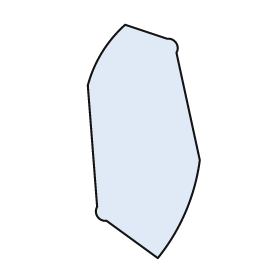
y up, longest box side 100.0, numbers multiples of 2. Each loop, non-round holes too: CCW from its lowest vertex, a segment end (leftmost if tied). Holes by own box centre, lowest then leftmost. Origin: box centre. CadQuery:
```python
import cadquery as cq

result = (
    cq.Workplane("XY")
    .moveTo(6.0, -50.0)
    .threePointArc((18.0, -30.0), (24.0, -8.0))
    .lineTo(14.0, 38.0)
    .threePointArc((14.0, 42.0), (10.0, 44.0))
    .lineTo(-8.0, 50.0)
    .threePointArc((-18.0, 38.0), (-24.0, 24.0))
    .lineTo(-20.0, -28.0)
    .threePointArc((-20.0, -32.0), (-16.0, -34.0))
    .close()
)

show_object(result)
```